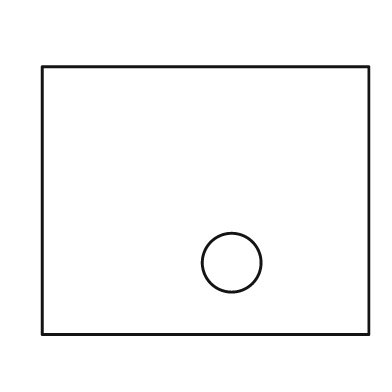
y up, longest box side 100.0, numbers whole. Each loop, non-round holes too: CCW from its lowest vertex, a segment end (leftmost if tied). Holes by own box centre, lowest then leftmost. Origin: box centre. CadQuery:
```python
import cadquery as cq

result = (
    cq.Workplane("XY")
    .moveTo(-50.0, -41.0)
    .lineTo(50.0, -41.0)
    .lineTo(50.0, 41.0)
    .lineTo(-50.0, 41.0)
    .close()
    .moveTo(8.0, -19.0)
    .circle(9.0)
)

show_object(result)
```